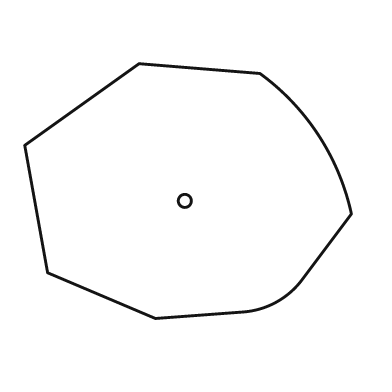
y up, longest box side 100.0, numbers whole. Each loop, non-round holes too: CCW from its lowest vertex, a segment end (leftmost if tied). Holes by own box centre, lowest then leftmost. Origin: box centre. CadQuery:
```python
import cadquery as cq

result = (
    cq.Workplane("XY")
    .moveTo(-10.0, -39.0)
    .lineTo(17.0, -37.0)
    .threePointArc((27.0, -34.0), (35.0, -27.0))
    .lineTo(50.0, -7.0)
    .threePointArc((40.0, 17.0), (22.0, 36.0))
    .lineTo(-15.0, 39.0)
    .lineTo(-50.0, 14.0)
    .lineTo(-43.0, -25.0)
    .close()
    .moveTo(-1.0, -3.0)
    .circle(2.0)
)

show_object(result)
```